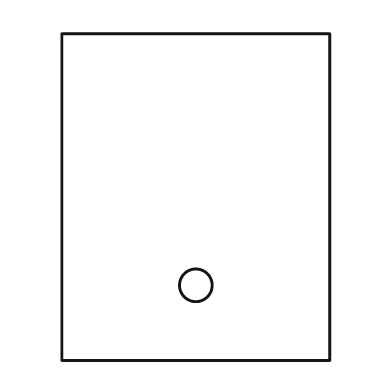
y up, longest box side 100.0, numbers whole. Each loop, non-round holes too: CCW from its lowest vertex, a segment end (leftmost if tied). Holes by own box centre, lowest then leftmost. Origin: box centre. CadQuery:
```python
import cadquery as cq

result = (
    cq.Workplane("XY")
    .moveTo(-41.0, -50.0)
    .lineTo(41.0, -50.0)
    .lineTo(41.0, 50.0)
    .lineTo(-41.0, 50.0)
    .close()
    .moveTo(0.0, -27.0)
    .circle(5.0)
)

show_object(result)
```